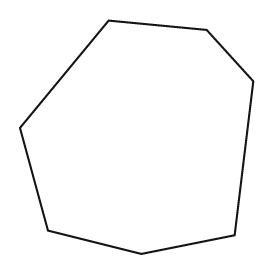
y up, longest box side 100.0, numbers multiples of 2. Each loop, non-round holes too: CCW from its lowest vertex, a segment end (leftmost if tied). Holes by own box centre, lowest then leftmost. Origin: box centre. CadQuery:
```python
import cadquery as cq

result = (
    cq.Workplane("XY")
    .moveTo(2.0, -50.0)
    .lineTo(42.0, -42.0)
    .lineTo(50.0, 24.0)
    .lineTo(30.0, 46.0)
    .lineTo(-12.0, 50.0)
    .lineTo(-50.0, 4.0)
    .lineTo(-38.0, -40.0)
    .close()
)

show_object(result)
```